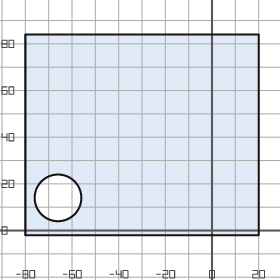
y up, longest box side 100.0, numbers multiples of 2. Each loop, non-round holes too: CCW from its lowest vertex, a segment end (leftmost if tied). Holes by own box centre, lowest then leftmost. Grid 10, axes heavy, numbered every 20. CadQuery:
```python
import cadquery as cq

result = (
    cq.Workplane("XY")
    .moveTo(-80.0, -2.0)
    .lineTo(20.0, -2.0)
    .lineTo(20.0, 84.0)
    .lineTo(-80.0, 84.0)
    .close()
    .moveTo(-66.0, 14.0)
    .circle(10.0)
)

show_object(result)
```